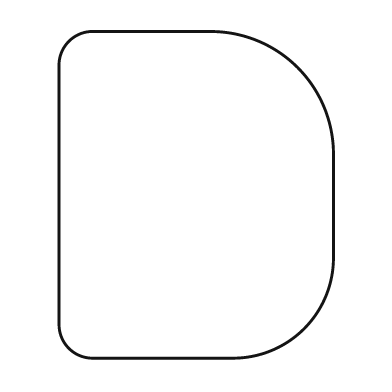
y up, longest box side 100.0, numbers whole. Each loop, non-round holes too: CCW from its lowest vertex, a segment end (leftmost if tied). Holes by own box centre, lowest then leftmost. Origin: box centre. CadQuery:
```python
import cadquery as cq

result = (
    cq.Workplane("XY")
    .moveTo(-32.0, -50.0)
    .lineTo(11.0, -50.0)
    .threePointArc((33.0, -41.0), (42.0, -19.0))
    .lineTo(42.0, 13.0)
    .threePointArc((31.0, 39.0), (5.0, 50.0))
    .lineTo(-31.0, 50.0)
    .threePointArc((-39.0, 47.0), (-42.0, 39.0))
    .lineTo(-42.0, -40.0)
    .threePointArc((-39.0, -47.0), (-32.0, -50.0))
    .close()
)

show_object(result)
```